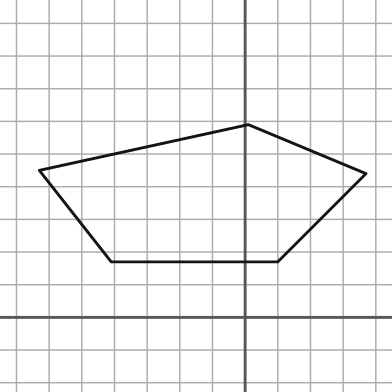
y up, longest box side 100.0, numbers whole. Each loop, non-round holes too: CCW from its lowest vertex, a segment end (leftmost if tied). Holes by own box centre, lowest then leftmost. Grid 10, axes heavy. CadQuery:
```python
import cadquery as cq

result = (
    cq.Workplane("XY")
    .moveTo(-41.0, 17.0)
    .lineTo(10.0, 17.0)
    .lineTo(37.0, 44.0)
    .lineTo(1.0, 59.0)
    .lineTo(-63.0, 45.0)
    .close()
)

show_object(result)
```